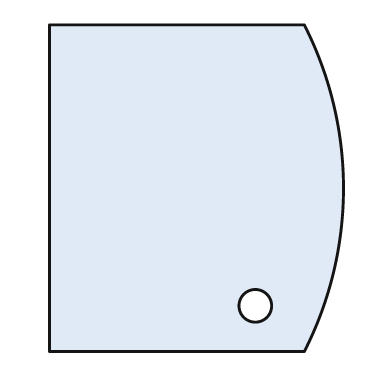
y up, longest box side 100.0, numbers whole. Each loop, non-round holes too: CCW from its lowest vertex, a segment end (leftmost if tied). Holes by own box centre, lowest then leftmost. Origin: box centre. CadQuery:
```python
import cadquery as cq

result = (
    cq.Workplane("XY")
    .moveTo(-45.0, -50.0)
    .lineTo(33.0, -50.0)
    .threePointArc((45.0, 0.0), (33.0, 50.0))
    .lineTo(-45.0, 50.0)
    .close()
    .moveTo(18.0, -36.0)
    .circle(5.0)
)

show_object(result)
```